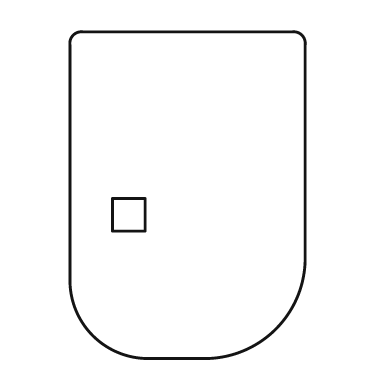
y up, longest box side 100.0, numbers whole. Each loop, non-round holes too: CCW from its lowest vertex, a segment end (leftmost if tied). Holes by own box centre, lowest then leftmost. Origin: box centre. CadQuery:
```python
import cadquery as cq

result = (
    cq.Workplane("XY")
    .moveTo(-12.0, -50.0)
    .lineTo(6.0, -50.0)
    .threePointArc((27.0, -41.0), (36.0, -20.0))
    .lineTo(36.0, 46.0)
    .threePointArc((35.0, 49.0), (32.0, 50.0))
    .lineTo(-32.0, 50.0)
    .threePointArc((-35.0, 49.0), (-36.0, 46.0))
    .lineTo(-36.0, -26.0)
    .threePointArc((-29.0, -43.0), (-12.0, -50.0))
    .close()
    .moveTo(-23.0, -11.0)
    .lineTo(-13.0, -11.0)
    .lineTo(-13.0, -1.0)
    .lineTo(-23.0, -1.0)
    .close()
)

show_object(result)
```